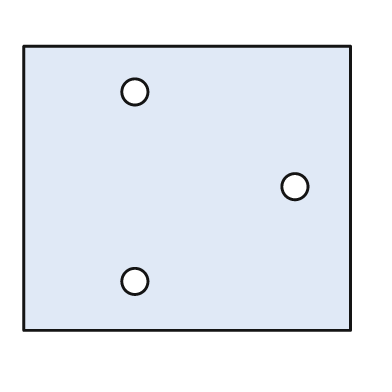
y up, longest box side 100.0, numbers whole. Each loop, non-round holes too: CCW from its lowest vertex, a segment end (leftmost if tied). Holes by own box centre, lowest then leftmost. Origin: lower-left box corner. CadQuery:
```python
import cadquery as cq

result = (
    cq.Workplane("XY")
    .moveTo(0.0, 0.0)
    .lineTo(100.0, 0.0)
    .lineTo(100.0, 87.0)
    .lineTo(0.0, 87.0)
    .close()
    .moveTo(34.0, 15.0)
    .circle(4.0)
    .moveTo(83.0, 44.0)
    .circle(4.0)
    .moveTo(34.0, 73.0)
    .circle(4.0)
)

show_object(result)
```